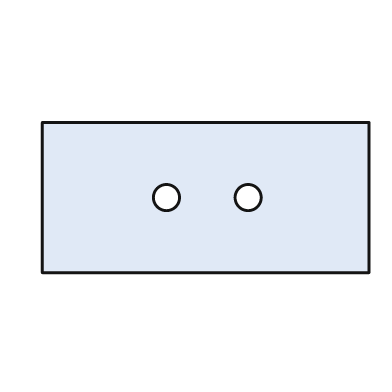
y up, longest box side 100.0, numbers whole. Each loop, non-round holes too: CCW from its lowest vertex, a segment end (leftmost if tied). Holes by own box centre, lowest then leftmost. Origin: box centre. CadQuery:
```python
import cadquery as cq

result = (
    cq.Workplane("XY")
    .moveTo(-50.0, -23.0)
    .lineTo(50.0, -23.0)
    .lineTo(50.0, 23.0)
    .lineTo(-50.0, 23.0)
    .close()
    .moveTo(-12.0, 0.0)
    .circle(4.0)
    .moveTo(13.0, 0.0)
    .circle(4.0)
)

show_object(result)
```